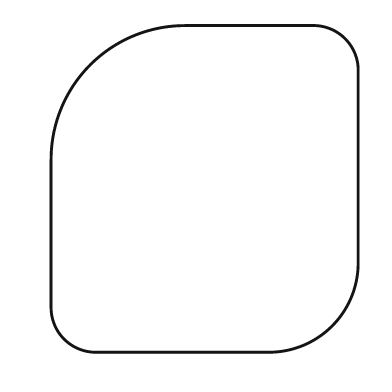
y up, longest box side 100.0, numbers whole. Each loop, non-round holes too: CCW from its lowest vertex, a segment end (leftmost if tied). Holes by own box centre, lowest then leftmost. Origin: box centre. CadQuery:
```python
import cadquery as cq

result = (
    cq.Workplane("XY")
    .moveTo(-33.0, -50.0)
    .lineTo(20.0, -50.0)
    .threePointArc((39.0, -42.0), (47.0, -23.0))
    .lineTo(47.0, 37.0)
    .threePointArc((43.0, 46.0), (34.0, 50.0))
    .lineTo(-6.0, 50.0)
    .threePointArc((-35.0, 38.0), (-47.0, 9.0))
    .lineTo(-47.0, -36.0)
    .threePointArc((-43.0, -46.0), (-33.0, -50.0))
    .close()
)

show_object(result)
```